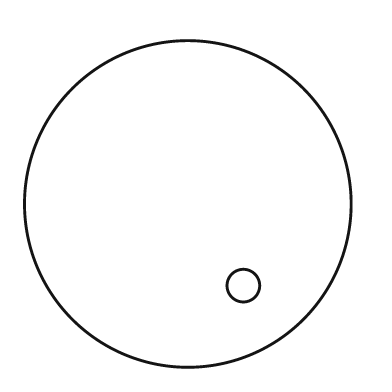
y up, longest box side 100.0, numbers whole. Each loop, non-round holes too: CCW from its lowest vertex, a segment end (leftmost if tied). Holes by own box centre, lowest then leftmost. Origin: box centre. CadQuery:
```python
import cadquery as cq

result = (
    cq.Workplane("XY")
    .moveTo(0.0, 0.0)
    .circle(50.0)
    .moveTo(17.0, -25.0)
    .circle(5.0)
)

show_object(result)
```